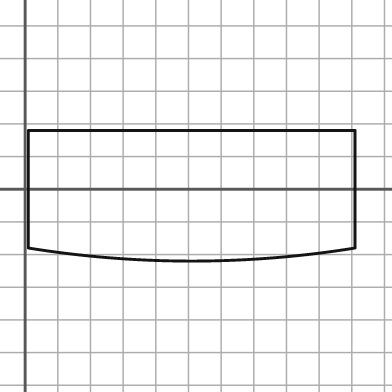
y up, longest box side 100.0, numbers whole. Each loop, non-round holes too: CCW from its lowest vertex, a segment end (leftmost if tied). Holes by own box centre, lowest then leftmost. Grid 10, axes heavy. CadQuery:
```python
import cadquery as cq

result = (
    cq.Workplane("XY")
    .moveTo(1.0, -18.0)
    .threePointArc((51.0, -22.0), (101.0, -18.0))
    .lineTo(101.0, 18.0)
    .lineTo(1.0, 18.0)
    .close()
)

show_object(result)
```